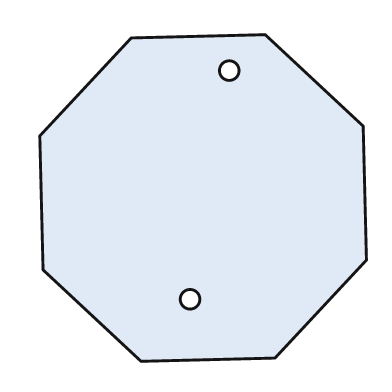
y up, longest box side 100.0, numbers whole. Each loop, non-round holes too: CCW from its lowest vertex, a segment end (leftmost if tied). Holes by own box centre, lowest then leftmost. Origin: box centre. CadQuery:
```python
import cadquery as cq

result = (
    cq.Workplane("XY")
    .moveTo(-19.0, -50.0)
    .lineTo(22.0, -49.0)
    .lineTo(50.0, -19.0)
    .lineTo(49.0, 22.0)
    .lineTo(19.0, 50.0)
    .lineTo(-22.0, 49.0)
    .lineTo(-50.0, 19.0)
    .lineTo(-49.0, -22.0)
    .close()
    .moveTo(-4.0, -31.0)
    .circle(3.0)
    .moveTo(8.0, 39.0)
    .circle(3.0)
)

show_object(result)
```